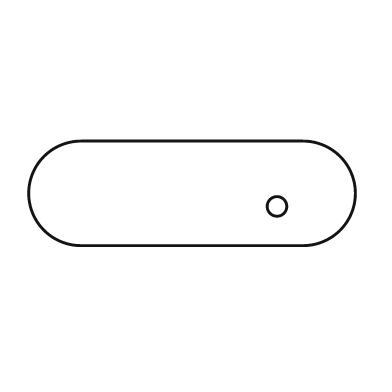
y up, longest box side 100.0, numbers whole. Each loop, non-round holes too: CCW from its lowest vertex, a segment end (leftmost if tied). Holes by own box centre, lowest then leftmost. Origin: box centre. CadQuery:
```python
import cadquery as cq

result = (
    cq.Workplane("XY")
    .moveTo(-34.0, -16.0)
    .lineTo(34.0, -16.0)
    .threePointArc((50.0, 0.0), (34.0, 16.0))
    .lineTo(-34.0, 16.0)
    .threePointArc((-50.0, 0.0), (-34.0, -16.0))
    .close()
    .moveTo(26.0, -4.0)
    .circle(3.0)
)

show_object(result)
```